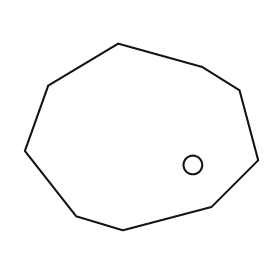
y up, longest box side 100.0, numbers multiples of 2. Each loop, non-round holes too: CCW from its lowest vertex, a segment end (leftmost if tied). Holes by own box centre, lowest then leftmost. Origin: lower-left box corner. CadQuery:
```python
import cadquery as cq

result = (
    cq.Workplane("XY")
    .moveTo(42.0, 0.0)
    .lineTo(80.0, 10.0)
    .lineTo(100.0, 30.0)
    .lineTo(92.0, 60.0)
    .lineTo(76.0, 70.0)
    .lineTo(40.0, 80.0)
    .lineTo(10.0, 62.0)
    .lineTo(0.0, 34.0)
    .lineTo(22.0, 6.0)
    .close()
    .moveTo(72.0, 28.0)
    .circle(4.0)
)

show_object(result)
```